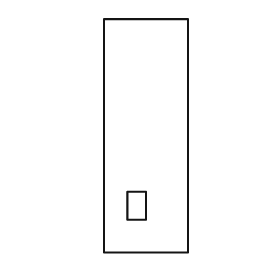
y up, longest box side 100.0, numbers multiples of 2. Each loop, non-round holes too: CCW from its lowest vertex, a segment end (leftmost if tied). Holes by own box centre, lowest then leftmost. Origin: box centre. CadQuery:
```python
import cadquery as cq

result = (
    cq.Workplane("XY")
    .moveTo(-18.0, -50.0)
    .lineTo(18.0, -50.0)
    .lineTo(18.0, 50.0)
    .lineTo(-18.0, 50.0)
    .close()
    .moveTo(-8.0, -36.0)
    .lineTo(0.0, -36.0)
    .lineTo(0.0, -24.0)
    .lineTo(-8.0, -24.0)
    .close()
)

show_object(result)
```